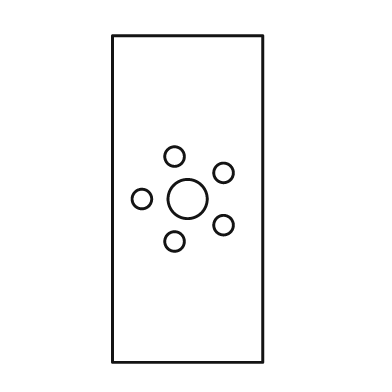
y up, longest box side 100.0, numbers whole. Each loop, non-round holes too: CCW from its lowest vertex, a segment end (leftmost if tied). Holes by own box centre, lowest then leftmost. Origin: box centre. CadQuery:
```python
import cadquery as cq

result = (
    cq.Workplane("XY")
    .moveTo(-23.0, -50.0)
    .lineTo(23.0, -50.0)
    .lineTo(23.0, 50.0)
    .lineTo(-23.0, 50.0)
    .close()
    .moveTo(-4.0, -13.0)
    .circle(3.0)
    .moveTo(11.0, -8.0)
    .circle(3.0)
    .moveTo(-14.0, 0.0)
    .circle(3.0)
    .moveTo(0.0, 0.0)
    .circle(6.0)
    .moveTo(11.0, 8.0)
    .circle(3.0)
    .moveTo(-4.0, 13.0)
    .circle(3.0)
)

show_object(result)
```